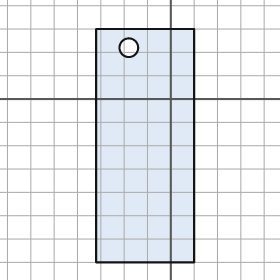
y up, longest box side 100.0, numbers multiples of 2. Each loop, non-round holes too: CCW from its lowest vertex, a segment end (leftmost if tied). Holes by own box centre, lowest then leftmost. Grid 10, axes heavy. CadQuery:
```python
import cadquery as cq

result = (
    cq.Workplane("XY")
    .moveTo(-32.0, -70.0)
    .lineTo(10.0, -70.0)
    .lineTo(10.0, 30.0)
    .lineTo(-32.0, 30.0)
    .close()
    .moveTo(-18.0, 22.0)
    .circle(4.0)
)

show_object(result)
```